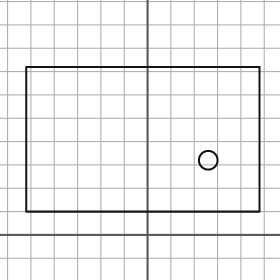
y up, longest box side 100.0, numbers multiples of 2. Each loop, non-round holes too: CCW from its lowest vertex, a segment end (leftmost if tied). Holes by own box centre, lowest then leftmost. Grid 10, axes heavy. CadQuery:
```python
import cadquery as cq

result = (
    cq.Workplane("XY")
    .moveTo(-52.0, 10.0)
    .lineTo(48.0, 10.0)
    .lineTo(48.0, 72.0)
    .lineTo(-52.0, 72.0)
    .close()
    .moveTo(26.0, 32.0)
    .circle(4.0)
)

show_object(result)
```